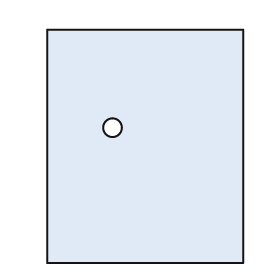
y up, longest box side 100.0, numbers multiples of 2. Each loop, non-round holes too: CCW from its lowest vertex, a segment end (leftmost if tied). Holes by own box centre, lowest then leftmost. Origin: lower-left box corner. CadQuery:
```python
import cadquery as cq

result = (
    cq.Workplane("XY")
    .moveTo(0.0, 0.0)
    .lineTo(84.0, 0.0)
    .lineTo(84.0, 100.0)
    .lineTo(0.0, 100.0)
    .close()
    .moveTo(28.0, 58.0)
    .circle(4.0)
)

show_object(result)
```